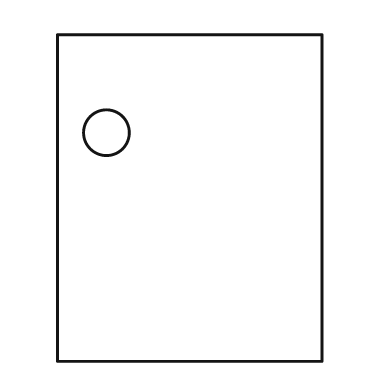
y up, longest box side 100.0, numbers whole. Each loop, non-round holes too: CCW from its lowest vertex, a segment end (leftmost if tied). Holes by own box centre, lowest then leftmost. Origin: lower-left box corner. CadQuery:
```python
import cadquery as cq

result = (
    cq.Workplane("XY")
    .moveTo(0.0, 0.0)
    .lineTo(81.0, 0.0)
    .lineTo(81.0, 100.0)
    .lineTo(0.0, 100.0)
    .close()
    .moveTo(15.0, 70.0)
    .circle(7.0)
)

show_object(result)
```